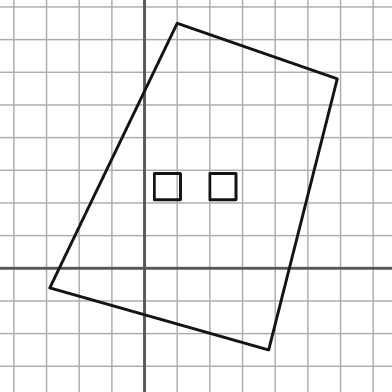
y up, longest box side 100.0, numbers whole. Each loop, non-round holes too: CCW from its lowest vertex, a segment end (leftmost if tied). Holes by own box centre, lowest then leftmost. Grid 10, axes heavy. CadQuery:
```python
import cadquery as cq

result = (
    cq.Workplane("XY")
    .moveTo(38.0, -25.0)
    .lineTo(59.0, 58.0)
    .lineTo(10.0, 75.0)
    .lineTo(-29.0, -6.0)
    .close()
    .moveTo(3.0, 21.0)
    .lineTo(11.0, 21.0)
    .lineTo(11.0, 29.0)
    .lineTo(3.0, 29.0)
    .close()
    .moveTo(20.0, 21.0)
    .lineTo(28.0, 21.0)
    .lineTo(28.0, 29.0)
    .lineTo(20.0, 29.0)
    .close()
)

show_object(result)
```